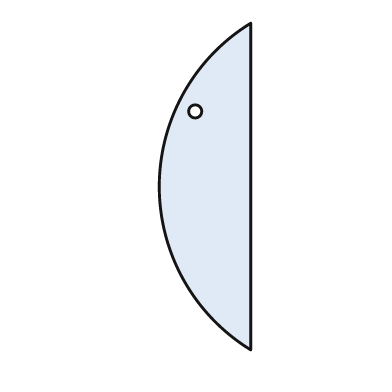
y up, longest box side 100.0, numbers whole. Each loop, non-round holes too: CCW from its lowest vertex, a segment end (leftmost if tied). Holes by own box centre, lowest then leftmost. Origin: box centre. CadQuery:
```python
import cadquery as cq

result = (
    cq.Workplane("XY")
    .moveTo(14.0, -50.0)
    .lineTo(14.0, 50.0)
    .threePointArc((-14.0, 0.0), (14.0, -50.0))
    .close()
    .moveTo(-3.0, 23.0)
    .circle(2.0)
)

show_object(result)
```